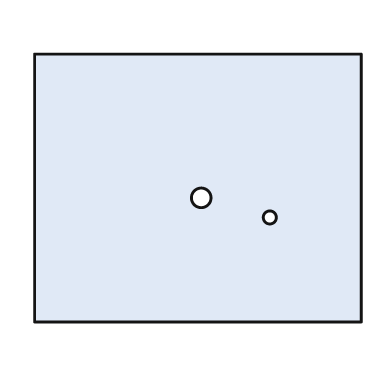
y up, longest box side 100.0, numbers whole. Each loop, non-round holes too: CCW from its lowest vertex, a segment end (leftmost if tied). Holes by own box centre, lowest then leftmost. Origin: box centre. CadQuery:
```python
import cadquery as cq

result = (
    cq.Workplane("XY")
    .moveTo(-50.0, -41.0)
    .lineTo(50.0, -41.0)
    .lineTo(50.0, 41.0)
    .lineTo(-50.0, 41.0)
    .close()
    .moveTo(22.0, -9.0)
    .circle(2.0)
    .moveTo(1.0, -3.0)
    .circle(3.0)
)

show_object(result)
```